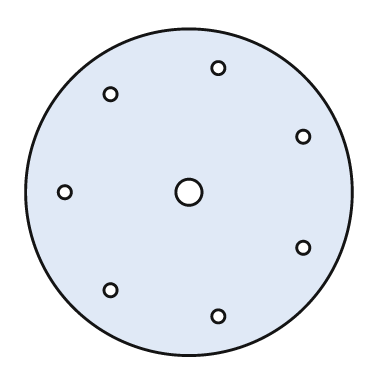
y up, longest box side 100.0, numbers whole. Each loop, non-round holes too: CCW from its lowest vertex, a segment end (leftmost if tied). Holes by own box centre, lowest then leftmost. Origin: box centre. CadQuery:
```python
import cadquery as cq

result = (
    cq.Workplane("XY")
    .moveTo(0.0, 0.0)
    .circle(50.0)
    .moveTo(9.0, -38.0)
    .circle(2.0)
    .moveTo(-24.0, -30.0)
    .circle(2.0)
    .moveTo(35.0, -17.0)
    .circle(2.0)
    .moveTo(-38.0, 0.0)
    .circle(2.0)
    .moveTo(0.0, 0.0)
    .circle(4.0)
    .moveTo(35.0, 17.0)
    .circle(2.0)
    .moveTo(-24.0, 30.0)
    .circle(2.0)
    .moveTo(9.0, 38.0)
    .circle(2.0)
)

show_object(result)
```